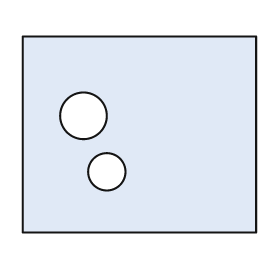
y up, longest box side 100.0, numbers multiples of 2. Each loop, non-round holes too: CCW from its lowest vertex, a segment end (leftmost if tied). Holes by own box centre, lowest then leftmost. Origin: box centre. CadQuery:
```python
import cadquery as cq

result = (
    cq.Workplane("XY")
    .moveTo(-50.0, -42.0)
    .lineTo(50.0, -42.0)
    .lineTo(50.0, 42.0)
    .lineTo(-50.0, 42.0)
    .close()
    .moveTo(-14.0, -16.0)
    .circle(8.0)
    .moveTo(-24.0, 8.0)
    .circle(10.0)
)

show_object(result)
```